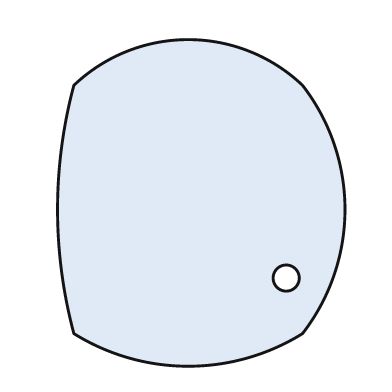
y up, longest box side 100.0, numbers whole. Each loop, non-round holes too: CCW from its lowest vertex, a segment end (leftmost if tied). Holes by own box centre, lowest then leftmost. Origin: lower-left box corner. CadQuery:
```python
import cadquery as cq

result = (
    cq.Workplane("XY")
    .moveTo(5.0, 10.0)
    .threePointArc((40.0, 0.0), (75.0, 10.0))
    .threePointArc((88.0, 48.0), (75.0, 86.0))
    .threePointArc((40.0, 100.0), (5.0, 86.0))
    .threePointArc((0.0, 48.0), (5.0, 10.0))
    .close()
    .moveTo(70.0, 27.0)
    .circle(4.0)
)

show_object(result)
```